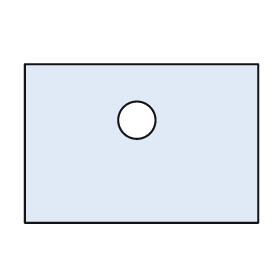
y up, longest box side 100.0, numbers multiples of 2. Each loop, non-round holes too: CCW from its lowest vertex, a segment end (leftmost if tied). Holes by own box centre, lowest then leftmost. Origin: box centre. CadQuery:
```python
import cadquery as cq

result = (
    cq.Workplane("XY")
    .moveTo(-50.0, -34.0)
    .lineTo(50.0, -34.0)
    .lineTo(50.0, 34.0)
    .lineTo(-50.0, 34.0)
    .close()
    .moveTo(-2.0, 10.0)
    .circle(8.0)
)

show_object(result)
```